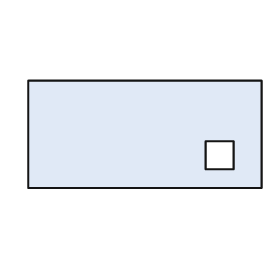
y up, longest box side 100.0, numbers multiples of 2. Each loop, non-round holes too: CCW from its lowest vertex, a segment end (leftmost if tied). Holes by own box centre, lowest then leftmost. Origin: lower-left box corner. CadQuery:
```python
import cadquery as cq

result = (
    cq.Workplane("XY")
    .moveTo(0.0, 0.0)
    .lineTo(100.0, 0.0)
    .lineTo(100.0, 46.0)
    .lineTo(0.0, 46.0)
    .close()
    .moveTo(76.0, 8.0)
    .lineTo(88.0, 8.0)
    .lineTo(88.0, 20.0)
    .lineTo(76.0, 20.0)
    .close()
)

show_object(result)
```